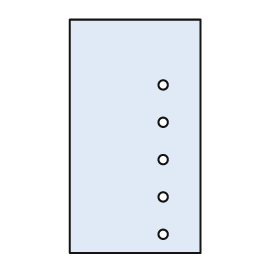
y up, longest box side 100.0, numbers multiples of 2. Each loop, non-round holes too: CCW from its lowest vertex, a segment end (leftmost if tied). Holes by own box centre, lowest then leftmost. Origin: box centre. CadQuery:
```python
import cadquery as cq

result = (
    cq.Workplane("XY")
    .moveTo(-28.0, -50.0)
    .lineTo(28.0, -50.0)
    .lineTo(28.0, 50.0)
    .lineTo(-28.0, 50.0)
    .close()
    .moveTo(12.0, -42.0)
    .circle(2.0)
    .moveTo(12.0, -26.0)
    .circle(2.0)
    .moveTo(12.0, -10.0)
    .circle(2.0)
    .moveTo(12.0, 6.0)
    .circle(2.0)
    .moveTo(12.0, 22.0)
    .circle(2.0)
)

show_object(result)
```